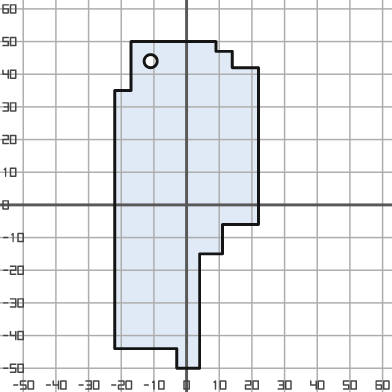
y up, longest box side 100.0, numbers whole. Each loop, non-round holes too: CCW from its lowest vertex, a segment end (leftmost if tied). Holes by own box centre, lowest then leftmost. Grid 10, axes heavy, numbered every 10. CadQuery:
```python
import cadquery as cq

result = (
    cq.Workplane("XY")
    .moveTo(-3.0, -50.0)
    .lineTo(4.0, -50.0)
    .lineTo(4.0, -15.0)
    .lineTo(11.0, -15.0)
    .lineTo(11.0, -6.0)
    .lineTo(22.0, -6.0)
    .lineTo(22.0, 42.0)
    .lineTo(14.0, 42.0)
    .lineTo(14.0, 47.0)
    .lineTo(9.0, 47.0)
    .lineTo(9.0, 50.0)
    .lineTo(-17.0, 50.0)
    .lineTo(-17.0, 35.0)
    .lineTo(-22.0, 35.0)
    .lineTo(-22.0, -44.0)
    .lineTo(-3.0, -44.0)
    .close()
    .moveTo(-11.0, 44.0)
    .circle(2.0)
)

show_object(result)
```